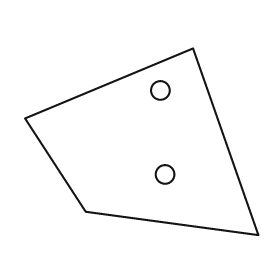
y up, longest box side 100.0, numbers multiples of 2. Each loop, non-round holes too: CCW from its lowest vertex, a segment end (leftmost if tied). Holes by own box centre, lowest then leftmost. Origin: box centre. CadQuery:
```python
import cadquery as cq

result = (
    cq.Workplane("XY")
    .moveTo(50.0, -40.0)
    .lineTo(22.0, 40.0)
    .lineTo(-50.0, 10.0)
    .lineTo(-24.0, -30.0)
    .close()
    .moveTo(10.0, -14.0)
    .circle(4.0)
    .moveTo(8.0, 22.0)
    .circle(4.0)
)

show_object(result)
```